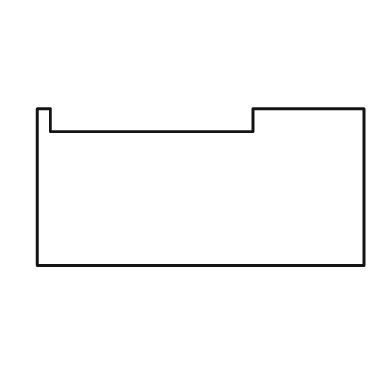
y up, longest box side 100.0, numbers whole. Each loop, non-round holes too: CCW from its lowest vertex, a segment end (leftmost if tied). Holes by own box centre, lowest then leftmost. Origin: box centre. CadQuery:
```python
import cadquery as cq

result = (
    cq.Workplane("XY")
    .moveTo(-50.0, -24.0)
    .lineTo(50.0, -24.0)
    .lineTo(50.0, 24.0)
    .lineTo(16.0, 24.0)
    .lineTo(16.0, 17.0)
    .lineTo(-46.0, 17.0)
    .lineTo(-46.0, 24.0)
    .lineTo(-50.0, 24.0)
    .close()
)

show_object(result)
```